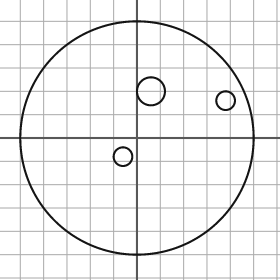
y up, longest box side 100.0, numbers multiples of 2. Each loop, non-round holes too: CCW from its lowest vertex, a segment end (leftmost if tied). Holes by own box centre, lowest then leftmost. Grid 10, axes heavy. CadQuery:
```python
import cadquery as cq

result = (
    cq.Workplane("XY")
    .moveTo(0.0, 0.0)
    .circle(50.0)
    .moveTo(-6.0, -8.0)
    .circle(4.0)
    .moveTo(38.0, 16.0)
    .circle(4.0)
    .moveTo(6.0, 20.0)
    .circle(6.0)
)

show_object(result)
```